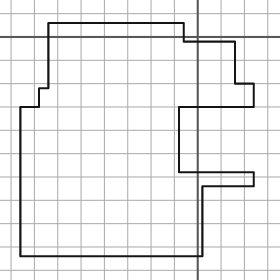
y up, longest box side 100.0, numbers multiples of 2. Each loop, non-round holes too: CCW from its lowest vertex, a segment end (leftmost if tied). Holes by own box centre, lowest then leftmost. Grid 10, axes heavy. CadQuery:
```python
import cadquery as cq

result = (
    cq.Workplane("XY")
    .moveTo(-76.0, -94.0)
    .lineTo(2.0, -94.0)
    .lineTo(2.0, -64.0)
    .lineTo(24.0, -64.0)
    .lineTo(24.0, -58.0)
    .lineTo(-8.0, -58.0)
    .lineTo(-8.0, -30.0)
    .lineTo(24.0, -30.0)
    .lineTo(24.0, -20.0)
    .lineTo(16.0, -20.0)
    .lineTo(16.0, -2.0)
    .lineTo(-6.0, -2.0)
    .lineTo(-6.0, 6.0)
    .lineTo(-64.0, 6.0)
    .lineTo(-64.0, -22.0)
    .lineTo(-68.0, -22.0)
    .lineTo(-68.0, -30.0)
    .lineTo(-76.0, -30.0)
    .close()
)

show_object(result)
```